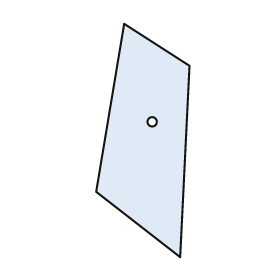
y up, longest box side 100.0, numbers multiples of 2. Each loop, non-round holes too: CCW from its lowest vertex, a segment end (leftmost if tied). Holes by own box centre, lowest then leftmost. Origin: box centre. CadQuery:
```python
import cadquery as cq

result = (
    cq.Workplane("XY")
    .moveTo(16.0, -50.0)
    .lineTo(20.0, 32.0)
    .lineTo(-8.0, 50.0)
    .lineTo(-20.0, -22.0)
    .close()
    .moveTo(4.0, 8.0)
    .circle(2.0)
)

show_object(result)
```